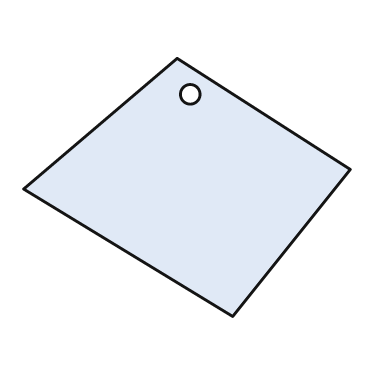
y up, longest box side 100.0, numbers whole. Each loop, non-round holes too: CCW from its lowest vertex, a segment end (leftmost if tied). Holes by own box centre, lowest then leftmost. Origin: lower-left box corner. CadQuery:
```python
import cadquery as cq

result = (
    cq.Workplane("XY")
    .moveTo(64.0, 0.0)
    .lineTo(100.0, 45.0)
    .lineTo(47.0, 79.0)
    .lineTo(0.0, 39.0)
    .close()
    .moveTo(51.0, 68.0)
    .circle(3.0)
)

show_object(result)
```